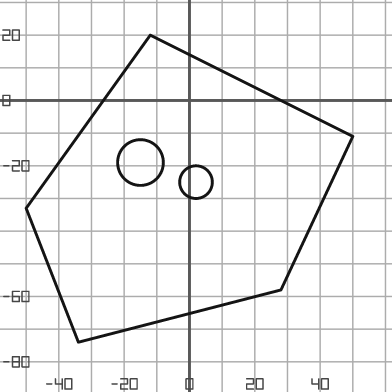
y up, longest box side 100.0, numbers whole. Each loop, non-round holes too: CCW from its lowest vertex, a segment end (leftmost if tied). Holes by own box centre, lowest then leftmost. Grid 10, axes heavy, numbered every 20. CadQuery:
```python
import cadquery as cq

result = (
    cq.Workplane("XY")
    .moveTo(-34.0, -74.0)
    .lineTo(28.0, -58.0)
    .lineTo(50.0, -11.0)
    .lineTo(-12.0, 20.0)
    .lineTo(-50.0, -33.0)
    .close()
    .moveTo(2.0, -25.0)
    .circle(5.0)
    .moveTo(-15.0, -19.0)
    .circle(7.0)
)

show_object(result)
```